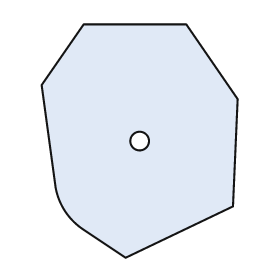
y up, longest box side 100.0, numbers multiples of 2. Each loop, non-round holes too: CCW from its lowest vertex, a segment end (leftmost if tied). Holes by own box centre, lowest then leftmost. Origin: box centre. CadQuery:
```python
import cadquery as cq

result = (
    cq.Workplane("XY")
    .moveTo(-6.0, -50.0)
    .lineTo(40.0, -28.0)
    .lineTo(42.0, 18.0)
    .lineTo(20.0, 50.0)
    .lineTo(-24.0, 50.0)
    .lineTo(-42.0, 24.0)
    .lineTo(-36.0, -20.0)
    .threePointArc((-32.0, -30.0), (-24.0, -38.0))
    .close()
    .moveTo(0.0, 0.0)
    .circle(4.0)
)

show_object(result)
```